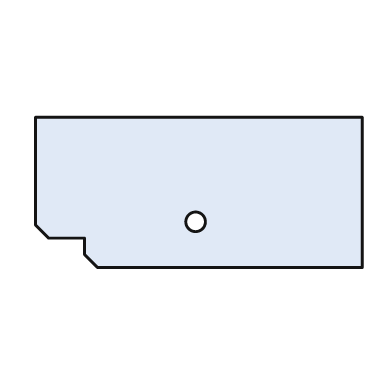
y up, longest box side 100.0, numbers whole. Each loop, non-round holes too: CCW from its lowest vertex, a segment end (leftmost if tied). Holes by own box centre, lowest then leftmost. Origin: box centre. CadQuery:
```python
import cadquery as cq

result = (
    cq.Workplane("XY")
    .moveTo(-31.0, -23.0)
    .lineTo(50.0, -23.0)
    .lineTo(50.0, 23.0)
    .lineTo(-50.0, 23.0)
    .lineTo(-50.0, -10.0)
    .lineTo(-46.0, -14.0)
    .lineTo(-35.0, -14.0)
    .lineTo(-35.0, -19.0)
    .close()
    .moveTo(-1.0, -9.0)
    .circle(3.0)
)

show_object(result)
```